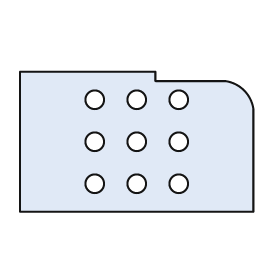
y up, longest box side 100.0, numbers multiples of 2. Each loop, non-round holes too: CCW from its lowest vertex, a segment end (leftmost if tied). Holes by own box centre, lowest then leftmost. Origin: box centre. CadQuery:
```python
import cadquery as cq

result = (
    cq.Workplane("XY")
    .moveTo(-50.0, -30.0)
    .lineTo(50.0, -30.0)
    .lineTo(50.0, 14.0)
    .threePointArc((46.0, 22.0), (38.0, 26.0))
    .lineTo(8.0, 26.0)
    .lineTo(8.0, 30.0)
    .lineTo(-50.0, 30.0)
    .close()
    .moveTo(-18.0, -18.0)
    .circle(4.0)
    .moveTo(0.0, -18.0)
    .circle(4.0)
    .moveTo(18.0, -18.0)
    .circle(4.0)
    .moveTo(-18.0, 0.0)
    .circle(4.0)
    .moveTo(0.0, 0.0)
    .circle(4.0)
    .moveTo(18.0, 0.0)
    .circle(4.0)
    .moveTo(-18.0, 18.0)
    .circle(4.0)
    .moveTo(0.0, 18.0)
    .circle(4.0)
    .moveTo(18.0, 18.0)
    .circle(4.0)
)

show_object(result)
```